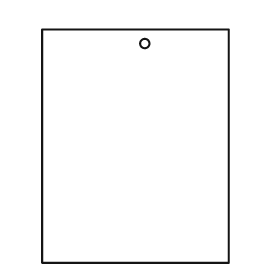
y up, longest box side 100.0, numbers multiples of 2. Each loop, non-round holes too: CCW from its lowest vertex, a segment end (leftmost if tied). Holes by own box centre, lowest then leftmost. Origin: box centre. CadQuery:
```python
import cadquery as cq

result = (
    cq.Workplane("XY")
    .moveTo(-40.0, -50.0)
    .lineTo(40.0, -50.0)
    .lineTo(40.0, 50.0)
    .lineTo(-40.0, 50.0)
    .close()
    .moveTo(4.0, 44.0)
    .circle(2.0)
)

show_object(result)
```